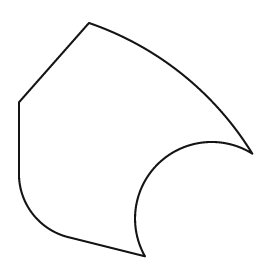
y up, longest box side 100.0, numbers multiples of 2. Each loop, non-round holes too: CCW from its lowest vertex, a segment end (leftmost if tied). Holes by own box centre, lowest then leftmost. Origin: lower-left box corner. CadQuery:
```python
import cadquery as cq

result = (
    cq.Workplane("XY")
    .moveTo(54.0, 0.0)
    .threePointArc((60.0, 40.0), (100.0, 44.0))
    .threePointArc((70.0, 78.0), (30.0, 100.0))
    .lineTo(0.0, 66.0)
    .lineTo(0.0, 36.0)
    .threePointArc((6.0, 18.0), (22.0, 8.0))
    .close()
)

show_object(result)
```